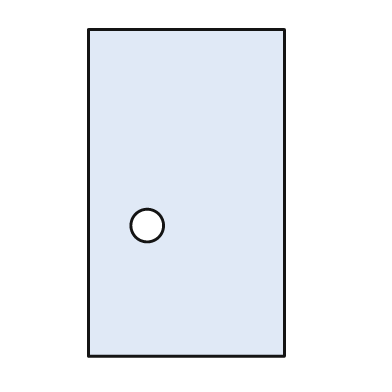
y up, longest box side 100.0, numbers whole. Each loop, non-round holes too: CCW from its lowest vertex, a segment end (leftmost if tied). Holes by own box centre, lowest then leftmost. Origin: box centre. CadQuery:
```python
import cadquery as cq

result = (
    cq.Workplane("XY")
    .moveTo(-30.0, -50.0)
    .lineTo(30.0, -50.0)
    .lineTo(30.0, 50.0)
    .lineTo(-30.0, 50.0)
    .close()
    .moveTo(-12.0, -10.0)
    .circle(5.0)
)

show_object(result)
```